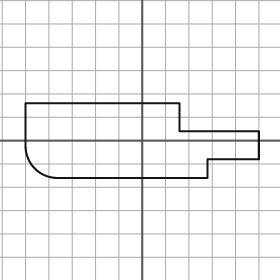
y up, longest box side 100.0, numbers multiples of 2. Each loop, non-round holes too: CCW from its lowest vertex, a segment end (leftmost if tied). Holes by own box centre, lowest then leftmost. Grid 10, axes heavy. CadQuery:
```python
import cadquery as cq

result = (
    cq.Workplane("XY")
    .moveTo(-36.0, -16.0)
    .lineTo(28.0, -16.0)
    .lineTo(28.0, -8.0)
    .lineTo(50.0, -8.0)
    .lineTo(50.0, 4.0)
    .lineTo(16.0, 4.0)
    .lineTo(16.0, 16.0)
    .lineTo(-50.0, 16.0)
    .lineTo(-50.0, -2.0)
    .threePointArc((-46.0, -12.0), (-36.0, -16.0))
    .close()
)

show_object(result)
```